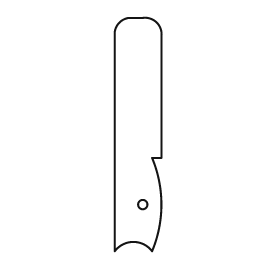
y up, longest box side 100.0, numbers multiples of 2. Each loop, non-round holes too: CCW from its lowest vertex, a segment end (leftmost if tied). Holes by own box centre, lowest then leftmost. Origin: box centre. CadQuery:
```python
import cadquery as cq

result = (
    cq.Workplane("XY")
    .moveTo(-10.0, -50.0)
    .threePointArc((-2.0, -46.0), (6.0, -50.0))
    .threePointArc((10.0, -30.0), (6.0, -10.0))
    .lineTo(10.0, -10.0)
    .lineTo(10.0, 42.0)
    .threePointArc((8.0, 48.0), (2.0, 50.0))
    .lineTo(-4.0, 50.0)
    .threePointArc((-8.0, 48.0), (-10.0, 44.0))
    .close()
    .moveTo(2.0, -30.0)
    .circle(2.0)
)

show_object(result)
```